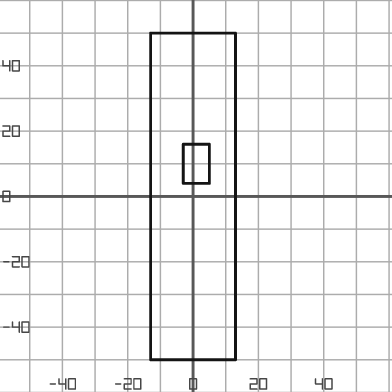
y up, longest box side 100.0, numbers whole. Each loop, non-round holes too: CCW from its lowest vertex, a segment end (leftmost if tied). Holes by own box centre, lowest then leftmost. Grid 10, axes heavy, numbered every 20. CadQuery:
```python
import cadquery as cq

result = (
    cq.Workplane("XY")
    .moveTo(-13.0, -50.0)
    .lineTo(13.0, -50.0)
    .lineTo(13.0, 50.0)
    .lineTo(-13.0, 50.0)
    .close()
    .moveTo(-3.0, 4.0)
    .lineTo(5.0, 4.0)
    .lineTo(5.0, 16.0)
    .lineTo(-3.0, 16.0)
    .close()
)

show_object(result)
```